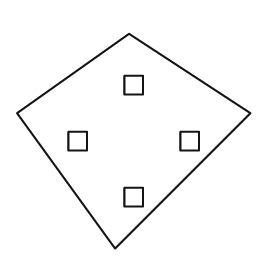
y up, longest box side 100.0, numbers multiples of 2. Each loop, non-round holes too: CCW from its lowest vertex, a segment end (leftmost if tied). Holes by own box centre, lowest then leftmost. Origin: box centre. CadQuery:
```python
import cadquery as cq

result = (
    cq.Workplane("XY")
    .moveTo(-8.0, -46.0)
    .lineTo(50.0, 12.0)
    .lineTo(-2.0, 46.0)
    .lineTo(-50.0, 12.0)
    .close()
    .moveTo(-4.0, -28.0)
    .lineTo(4.0, -28.0)
    .lineTo(4.0, -20.0)
    .lineTo(-4.0, -20.0)
    .close()
    .moveTo(-28.0, -4.0)
    .lineTo(-20.0, -4.0)
    .lineTo(-20.0, 4.0)
    .lineTo(-28.0, 4.0)
    .close()
    .moveTo(20.0, -4.0)
    .lineTo(28.0, -4.0)
    .lineTo(28.0, 4.0)
    .lineTo(20.0, 4.0)
    .close()
    .moveTo(-4.0, 20.0)
    .lineTo(4.0, 20.0)
    .lineTo(4.0, 28.0)
    .lineTo(-4.0, 28.0)
    .close()
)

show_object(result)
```